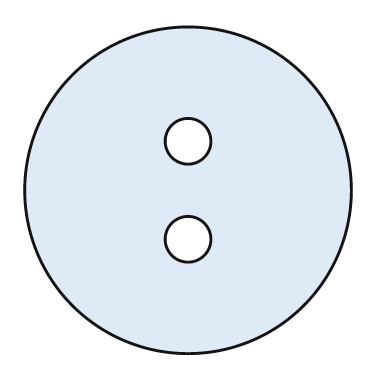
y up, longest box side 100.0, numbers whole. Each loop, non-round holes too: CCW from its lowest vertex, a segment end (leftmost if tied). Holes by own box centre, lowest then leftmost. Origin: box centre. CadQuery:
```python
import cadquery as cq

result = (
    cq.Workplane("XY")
    .moveTo(0.0, 0.0)
    .circle(50.0)
    .moveTo(0.0, -15.0)
    .circle(7.0)
    .moveTo(0.0, 15.0)
    .circle(7.0)
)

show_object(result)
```